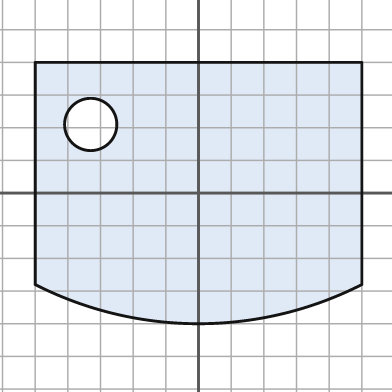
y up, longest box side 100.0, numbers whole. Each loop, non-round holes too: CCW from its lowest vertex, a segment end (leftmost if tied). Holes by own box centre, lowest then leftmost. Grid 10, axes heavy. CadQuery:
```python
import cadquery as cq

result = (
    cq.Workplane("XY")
    .moveTo(-50.0, -28.0)
    .threePointArc((0.0, -40.0), (50.0, -28.0))
    .lineTo(50.0, 40.0)
    .lineTo(-50.0, 40.0)
    .close()
    .moveTo(-33.0, 21.0)
    .circle(8.0)
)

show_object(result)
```